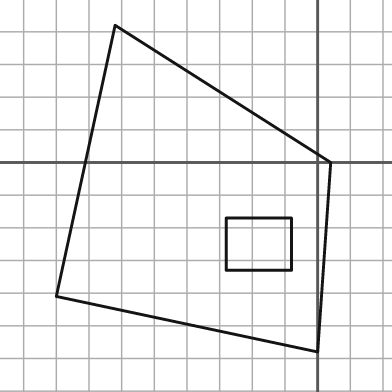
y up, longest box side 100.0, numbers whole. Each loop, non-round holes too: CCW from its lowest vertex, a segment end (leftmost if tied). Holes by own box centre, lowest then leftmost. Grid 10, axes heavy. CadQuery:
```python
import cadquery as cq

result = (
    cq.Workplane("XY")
    .moveTo(0.0, -58.0)
    .lineTo(4.0, 0.0)
    .lineTo(-62.0, 42.0)
    .lineTo(-80.0, -41.0)
    .close()
    .moveTo(-28.0, -33.0)
    .lineTo(-8.0, -33.0)
    .lineTo(-8.0, -17.0)
    .lineTo(-28.0, -17.0)
    .close()
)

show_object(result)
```